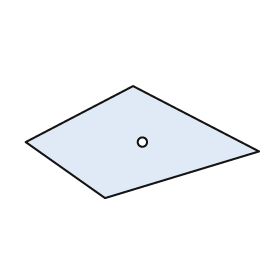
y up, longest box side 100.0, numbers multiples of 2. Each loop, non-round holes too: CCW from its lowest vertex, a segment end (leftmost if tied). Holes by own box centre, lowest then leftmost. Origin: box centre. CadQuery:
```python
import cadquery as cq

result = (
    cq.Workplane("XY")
    .moveTo(-16.0, -24.0)
    .lineTo(50.0, -4.0)
    .lineTo(-4.0, 24.0)
    .lineTo(-50.0, 0.0)
    .close()
    .moveTo(0.0, 0.0)
    .circle(2.0)
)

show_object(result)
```